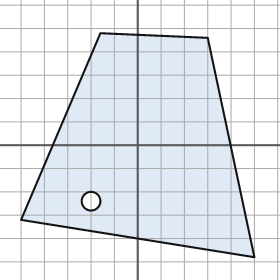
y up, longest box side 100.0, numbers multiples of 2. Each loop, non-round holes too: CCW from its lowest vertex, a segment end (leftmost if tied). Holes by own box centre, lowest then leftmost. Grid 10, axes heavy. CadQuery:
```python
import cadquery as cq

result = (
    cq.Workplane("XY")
    .moveTo(50.0, -48.0)
    .lineTo(30.0, 46.0)
    .lineTo(-16.0, 48.0)
    .lineTo(-50.0, -32.0)
    .close()
    .moveTo(-20.0, -24.0)
    .circle(4.0)
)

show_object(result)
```